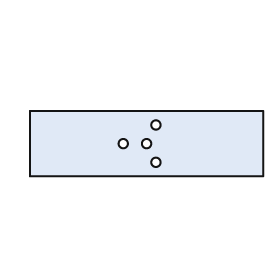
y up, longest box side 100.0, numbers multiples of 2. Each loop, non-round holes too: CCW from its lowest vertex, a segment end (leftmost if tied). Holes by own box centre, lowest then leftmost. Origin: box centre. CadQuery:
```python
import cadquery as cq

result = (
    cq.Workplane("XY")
    .moveTo(-50.0, -14.0)
    .lineTo(50.0, -14.0)
    .lineTo(50.0, 14.0)
    .lineTo(-50.0, 14.0)
    .close()
    .moveTo(4.0, -8.0)
    .circle(2.0)
    .moveTo(-10.0, 0.0)
    .circle(2.0)
    .moveTo(0.0, 0.0)
    .circle(2.0)
    .moveTo(4.0, 8.0)
    .circle(2.0)
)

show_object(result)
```